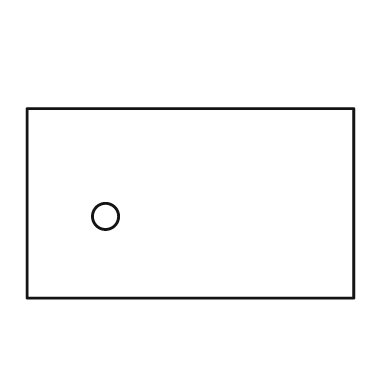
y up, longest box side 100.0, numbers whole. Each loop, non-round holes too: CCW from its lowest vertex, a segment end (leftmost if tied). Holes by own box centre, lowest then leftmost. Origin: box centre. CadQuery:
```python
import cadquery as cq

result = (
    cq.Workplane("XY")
    .moveTo(-50.0, -29.0)
    .lineTo(50.0, -29.0)
    .lineTo(50.0, 29.0)
    .lineTo(-50.0, 29.0)
    .close()
    .moveTo(-26.0, -4.0)
    .circle(4.0)
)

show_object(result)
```